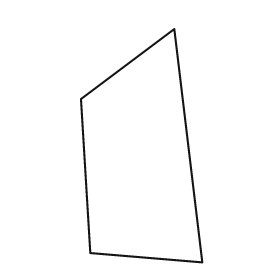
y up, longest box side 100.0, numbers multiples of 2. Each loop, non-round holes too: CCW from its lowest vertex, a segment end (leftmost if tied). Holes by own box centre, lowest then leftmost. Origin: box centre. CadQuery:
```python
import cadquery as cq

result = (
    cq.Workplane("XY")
    .moveTo(26.0, -50.0)
    .lineTo(14.0, 50.0)
    .lineTo(-26.0, 20.0)
    .lineTo(-22.0, -46.0)
    .close()
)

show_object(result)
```